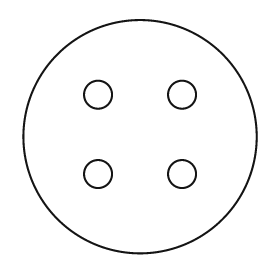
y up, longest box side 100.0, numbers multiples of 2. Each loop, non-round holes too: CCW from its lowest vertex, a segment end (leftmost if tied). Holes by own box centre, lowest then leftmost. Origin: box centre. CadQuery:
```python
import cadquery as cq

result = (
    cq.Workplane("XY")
    .moveTo(0.0, 0.0)
    .circle(50.0)
    .moveTo(-18.0, -16.0)
    .circle(6.0)
    .moveTo(18.0, -16.0)
    .circle(6.0)
    .moveTo(-18.0, 18.0)
    .circle(6.0)
    .moveTo(18.0, 18.0)
    .circle(6.0)
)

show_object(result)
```